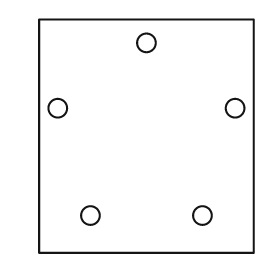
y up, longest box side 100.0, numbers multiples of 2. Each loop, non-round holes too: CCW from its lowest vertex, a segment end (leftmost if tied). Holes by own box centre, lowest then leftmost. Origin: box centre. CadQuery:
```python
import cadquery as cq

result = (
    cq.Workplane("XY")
    .moveTo(-46.0, -50.0)
    .lineTo(46.0, -50.0)
    .lineTo(46.0, 50.0)
    .lineTo(-46.0, 50.0)
    .close()
    .moveTo(-24.0, -34.0)
    .circle(4.0)
    .moveTo(24.0, -34.0)
    .circle(4.0)
    .moveTo(-38.0, 12.0)
    .circle(4.0)
    .moveTo(38.0, 12.0)
    .circle(4.0)
    .moveTo(0.0, 40.0)
    .circle(4.0)
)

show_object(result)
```